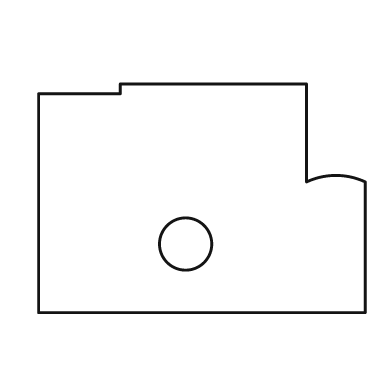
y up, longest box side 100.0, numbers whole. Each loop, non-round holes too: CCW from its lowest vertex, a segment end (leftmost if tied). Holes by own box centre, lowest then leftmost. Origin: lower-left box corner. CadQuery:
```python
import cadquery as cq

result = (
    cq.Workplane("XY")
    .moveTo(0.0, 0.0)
    .lineTo(100.0, 0.0)
    .lineTo(100.0, 40.0)
    .threePointArc((91.0, 42.0), (82.0, 40.0))
    .lineTo(82.0, 70.0)
    .lineTo(25.0, 70.0)
    .lineTo(25.0, 67.0)
    .lineTo(0.0, 67.0)
    .close()
    .moveTo(45.0, 21.0)
    .circle(8.0)
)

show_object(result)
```